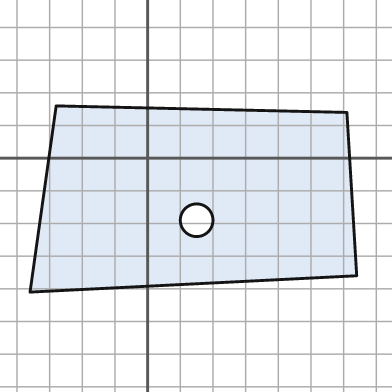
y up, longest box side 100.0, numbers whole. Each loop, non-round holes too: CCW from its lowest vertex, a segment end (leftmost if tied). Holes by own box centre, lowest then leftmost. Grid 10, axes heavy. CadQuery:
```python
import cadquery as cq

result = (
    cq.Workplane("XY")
    .moveTo(-36.0, -41.0)
    .lineTo(64.0, -36.0)
    .lineTo(61.0, 14.0)
    .lineTo(-28.0, 16.0)
    .close()
    .moveTo(15.0, -19.0)
    .circle(5.0)
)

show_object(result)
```